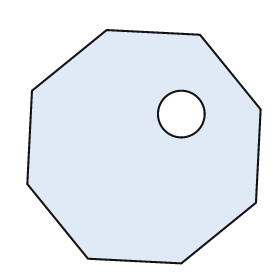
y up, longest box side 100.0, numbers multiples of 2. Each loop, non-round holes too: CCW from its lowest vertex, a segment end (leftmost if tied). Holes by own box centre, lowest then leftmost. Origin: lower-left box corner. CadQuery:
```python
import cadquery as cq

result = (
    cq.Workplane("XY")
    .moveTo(66.0, 0.0)
    .lineTo(98.0, 26.0)
    .lineTo(100.0, 66.0)
    .lineTo(74.0, 98.0)
    .lineTo(34.0, 100.0)
    .lineTo(2.0, 74.0)
    .lineTo(0.0, 34.0)
    .lineTo(26.0, 2.0)
    .close()
    .moveTo(66.0, 64.0)
    .circle(10.0)
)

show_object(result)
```